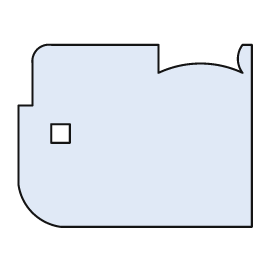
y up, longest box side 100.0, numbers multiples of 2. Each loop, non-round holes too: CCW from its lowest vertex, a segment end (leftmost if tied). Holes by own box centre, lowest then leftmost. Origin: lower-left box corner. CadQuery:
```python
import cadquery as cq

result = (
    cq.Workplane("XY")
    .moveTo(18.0, 0.0)
    .lineTo(100.0, 0.0)
    .lineTo(100.0, 78.0)
    .lineTo(96.0, 78.0)
    .threePointArc((94.0, 72.0), (96.0, 66.0))
    .threePointArc((78.0, 70.0), (60.0, 66.0))
    .lineTo(60.0, 78.0)
    .lineTo(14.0, 78.0)
    .threePointArc((8.0, 76.0), (6.0, 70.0))
    .lineTo(6.0, 52.0)
    .lineTo(0.0, 52.0)
    .lineTo(0.0, 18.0)
    .threePointArc((6.0, 6.0), (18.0, 0.0))
    .close()
    .moveTo(14.0, 36.0)
    .lineTo(22.0, 36.0)
    .lineTo(22.0, 44.0)
    .lineTo(14.0, 44.0)
    .close()
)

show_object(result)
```